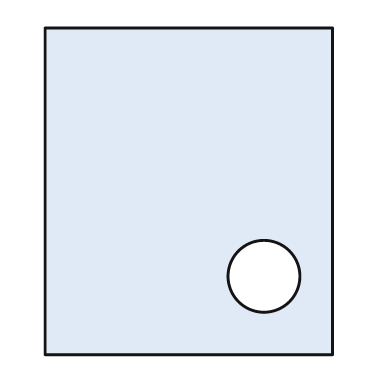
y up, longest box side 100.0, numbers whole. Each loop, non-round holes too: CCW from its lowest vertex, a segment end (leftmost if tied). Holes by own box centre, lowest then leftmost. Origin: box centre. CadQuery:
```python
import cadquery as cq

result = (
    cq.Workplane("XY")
    .moveTo(-44.0, -50.0)
    .lineTo(44.0, -50.0)
    .lineTo(44.0, 50.0)
    .lineTo(-44.0, 50.0)
    .close()
    .moveTo(23.0, -26.0)
    .circle(11.0)
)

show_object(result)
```